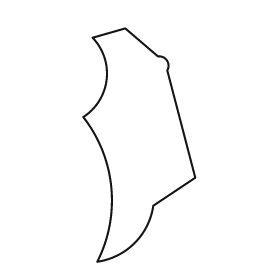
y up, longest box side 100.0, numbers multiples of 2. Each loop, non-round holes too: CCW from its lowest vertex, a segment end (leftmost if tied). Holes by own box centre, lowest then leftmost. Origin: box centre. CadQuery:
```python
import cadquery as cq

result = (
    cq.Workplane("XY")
    .moveTo(-18.0, -50.0)
    .threePointArc((-2.0, -42.0), (6.0, -26.0))
    .lineTo(24.0, -14.0)
    .lineTo(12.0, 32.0)
    .threePointArc((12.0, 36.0), (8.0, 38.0))
    .lineTo(-6.0, 50.0)
    .lineTo(-20.0, 46.0)
    .threePointArc((-14.0, 28.0), (-24.0, 12.0))
    .threePointArc((-12.0, -18.0), (-18.0, -50.0))
    .close()
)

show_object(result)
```